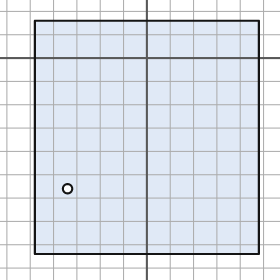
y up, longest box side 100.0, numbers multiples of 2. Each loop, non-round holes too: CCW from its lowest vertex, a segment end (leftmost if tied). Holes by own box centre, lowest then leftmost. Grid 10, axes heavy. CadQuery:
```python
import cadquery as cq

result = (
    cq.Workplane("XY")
    .moveTo(-48.0, -84.0)
    .lineTo(48.0, -84.0)
    .lineTo(48.0, 16.0)
    .lineTo(-48.0, 16.0)
    .close()
    .moveTo(-34.0, -56.0)
    .circle(2.0)
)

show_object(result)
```